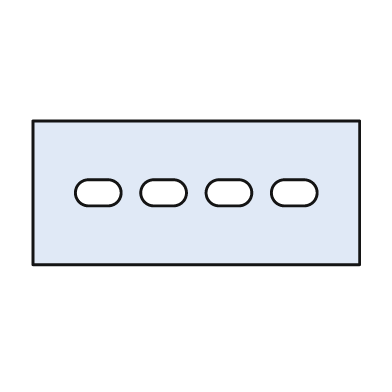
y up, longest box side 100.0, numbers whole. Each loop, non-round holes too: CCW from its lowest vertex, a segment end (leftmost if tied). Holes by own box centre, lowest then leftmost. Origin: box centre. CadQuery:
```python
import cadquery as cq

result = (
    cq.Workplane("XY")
    .moveTo(-50.0, -22.0)
    .lineTo(50.0, -22.0)
    .lineTo(50.0, 22.0)
    .lineTo(-50.0, 22.0)
    .close()
    .moveTo(-33.0, -4.0)
    .lineTo(-27.0, -4.0)
    .threePointArc((-23.0, 0.0), (-27.0, 4.0))
    .lineTo(-33.0, 4.0)
    .threePointArc((-37.0, 0.0), (-33.0, -4.0))
    .close()
    .moveTo(-13.0, -4.0)
    .lineTo(-7.0, -4.0)
    .threePointArc((-3.0, 0.0), (-7.0, 4.0))
    .lineTo(-13.0, 4.0)
    .threePointArc((-17.0, 0.0), (-13.0, -4.0))
    .close()
    .moveTo(7.0, -4.0)
    .lineTo(13.0, -4.0)
    .threePointArc((17.0, 0.0), (13.0, 4.0))
    .lineTo(7.0, 4.0)
    .threePointArc((3.0, 0.0), (7.0, -4.0))
    .close()
    .moveTo(27.0, -4.0)
    .lineTo(33.0, -4.0)
    .threePointArc((37.0, 0.0), (33.0, 4.0))
    .lineTo(27.0, 4.0)
    .threePointArc((23.0, 0.0), (27.0, -4.0))
    .close()
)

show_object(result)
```